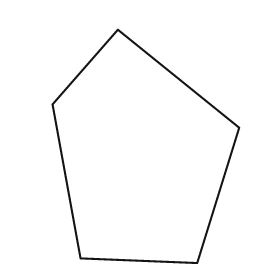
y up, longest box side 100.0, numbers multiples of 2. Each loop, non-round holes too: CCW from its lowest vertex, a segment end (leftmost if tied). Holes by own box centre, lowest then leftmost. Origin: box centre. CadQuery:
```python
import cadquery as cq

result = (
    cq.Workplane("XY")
    .moveTo(22.0, -50.0)
    .lineTo(40.0, 8.0)
    .lineTo(-12.0, 50.0)
    .lineTo(-40.0, 18.0)
    .lineTo(-28.0, -48.0)
    .close()
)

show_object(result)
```